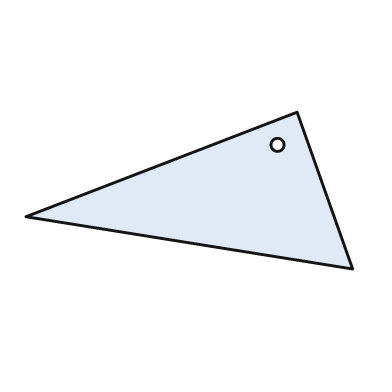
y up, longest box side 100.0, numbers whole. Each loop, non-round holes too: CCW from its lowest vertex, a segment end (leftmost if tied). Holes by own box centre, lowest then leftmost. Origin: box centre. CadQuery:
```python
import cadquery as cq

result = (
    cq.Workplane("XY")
    .moveTo(50.0, -24.0)
    .lineTo(33.0, 24.0)
    .lineTo(-50.0, -8.0)
    .close()
    .moveTo(27.0, 14.0)
    .circle(2.0)
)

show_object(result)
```